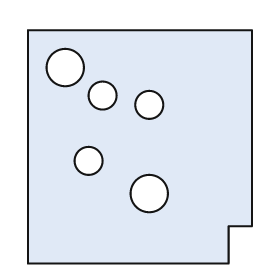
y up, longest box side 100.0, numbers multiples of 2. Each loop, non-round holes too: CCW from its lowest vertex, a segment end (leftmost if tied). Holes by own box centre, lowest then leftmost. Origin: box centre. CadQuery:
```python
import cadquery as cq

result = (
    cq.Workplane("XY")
    .moveTo(-48.0, -50.0)
    .lineTo(38.0, -50.0)
    .lineTo(38.0, -34.0)
    .lineTo(48.0, -34.0)
    .lineTo(48.0, 50.0)
    .lineTo(-48.0, 50.0)
    .close()
    .moveTo(4.0, -20.0)
    .circle(8.0)
    .moveTo(-22.0, -6.0)
    .circle(6.0)
    .moveTo(4.0, 18.0)
    .circle(6.0)
    .moveTo(-16.0, 22.0)
    .circle(6.0)
    .moveTo(-32.0, 34.0)
    .circle(8.0)
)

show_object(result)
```